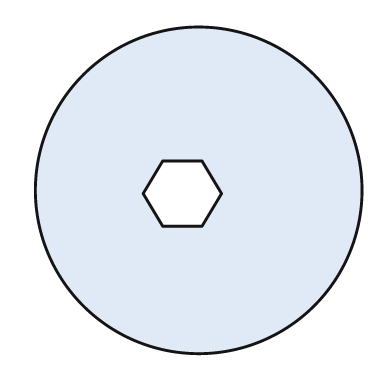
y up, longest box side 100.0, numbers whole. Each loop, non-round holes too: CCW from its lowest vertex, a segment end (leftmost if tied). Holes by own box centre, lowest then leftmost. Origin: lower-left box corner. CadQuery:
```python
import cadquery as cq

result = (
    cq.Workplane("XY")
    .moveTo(50.0, 50.0)
    .circle(50.0)
    .moveTo(39.0, 39.0)
    .lineTo(51.0, 39.0)
    .lineTo(57.0, 49.0)
    .lineTo(51.0, 59.0)
    .lineTo(39.0, 59.0)
    .lineTo(33.0, 49.0)
    .close()
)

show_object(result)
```